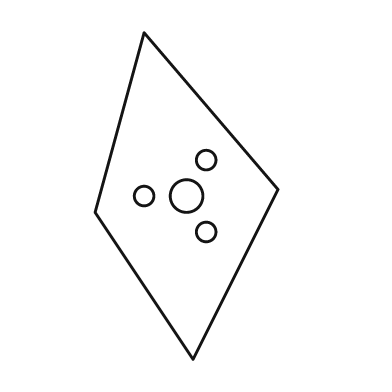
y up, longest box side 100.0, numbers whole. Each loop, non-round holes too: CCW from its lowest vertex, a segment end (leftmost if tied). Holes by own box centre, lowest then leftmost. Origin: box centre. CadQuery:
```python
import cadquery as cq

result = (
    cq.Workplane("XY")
    .moveTo(2.0, -50.0)
    .lineTo(28.0, 2.0)
    .lineTo(-13.0, 50.0)
    .lineTo(-28.0, -5.0)
    .close()
    .moveTo(6.0, -11.0)
    .circle(3.0)
    .moveTo(-13.0, 0.0)
    .circle(3.0)
    .moveTo(0.0, 0.0)
    .circle(5.0)
    .moveTo(6.0, 11.0)
    .circle(3.0)
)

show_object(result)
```